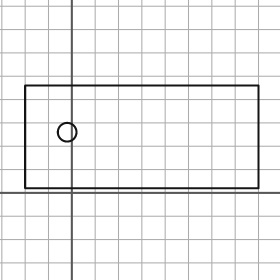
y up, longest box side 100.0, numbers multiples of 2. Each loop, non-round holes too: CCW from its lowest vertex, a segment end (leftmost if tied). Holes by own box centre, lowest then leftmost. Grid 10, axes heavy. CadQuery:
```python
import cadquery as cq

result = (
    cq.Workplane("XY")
    .moveTo(-20.0, 2.0)
    .lineTo(80.0, 2.0)
    .lineTo(80.0, 46.0)
    .lineTo(-20.0, 46.0)
    .close()
    .moveTo(-2.0, 26.0)
    .circle(4.0)
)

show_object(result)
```